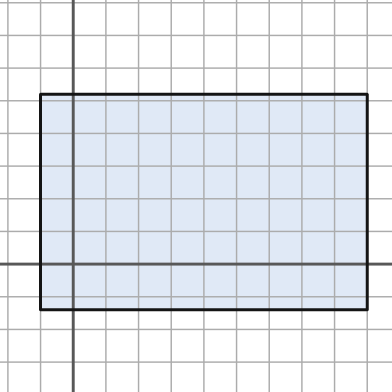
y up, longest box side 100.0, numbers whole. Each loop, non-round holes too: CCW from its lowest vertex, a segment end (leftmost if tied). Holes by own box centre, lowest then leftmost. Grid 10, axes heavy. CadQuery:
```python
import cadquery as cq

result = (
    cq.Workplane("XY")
    .moveTo(-10.0, -14.0)
    .lineTo(90.0, -14.0)
    .lineTo(90.0, 52.0)
    .lineTo(-10.0, 52.0)
    .close()
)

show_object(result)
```